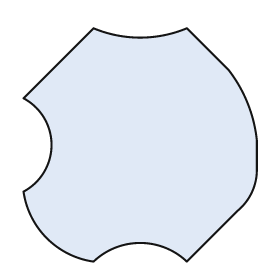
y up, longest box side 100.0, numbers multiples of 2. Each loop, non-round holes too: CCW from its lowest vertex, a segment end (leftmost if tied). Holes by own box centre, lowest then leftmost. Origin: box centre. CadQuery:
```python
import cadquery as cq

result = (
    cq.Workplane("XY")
    .moveTo(-20.0, -50.0)
    .threePointArc((0.0, -42.0), (20.0, -50.0))
    .lineTo(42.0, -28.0)
    .threePointArc((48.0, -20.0), (50.0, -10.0))
    .lineTo(50.0, 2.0)
    .threePointArc((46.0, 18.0), (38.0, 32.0))
    .lineTo(20.0, 50.0)
    .threePointArc((0.0, 46.0), (-20.0, 50.0))
    .lineTo(-50.0, 20.0)
    .threePointArc((-38.0, 0.0), (-50.0, -20.0))
    .threePointArc((-40.0, -40.0), (-20.0, -50.0))
    .close()
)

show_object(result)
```